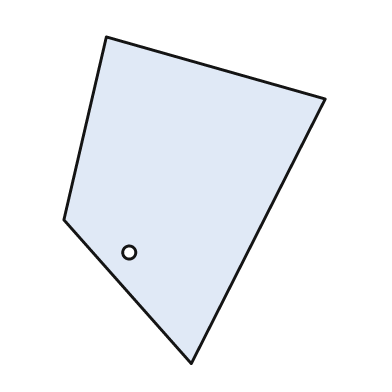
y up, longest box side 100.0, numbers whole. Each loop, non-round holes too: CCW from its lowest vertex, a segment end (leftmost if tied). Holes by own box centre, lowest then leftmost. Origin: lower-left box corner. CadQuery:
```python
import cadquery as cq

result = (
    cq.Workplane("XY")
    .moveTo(39.0, 0.0)
    .lineTo(80.0, 81.0)
    .lineTo(13.0, 100.0)
    .lineTo(0.0, 44.0)
    .close()
    .moveTo(20.0, 34.0)
    .circle(2.0)
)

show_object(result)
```